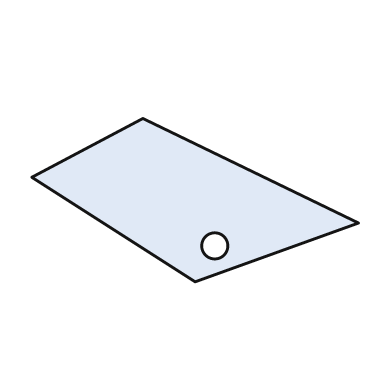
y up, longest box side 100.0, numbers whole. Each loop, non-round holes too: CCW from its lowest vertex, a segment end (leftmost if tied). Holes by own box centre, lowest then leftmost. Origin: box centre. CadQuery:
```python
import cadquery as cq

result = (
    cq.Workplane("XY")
    .moveTo(0.0, -25.0)
    .lineTo(50.0, -7.0)
    .lineTo(-16.0, 25.0)
    .lineTo(-50.0, 7.0)
    .close()
    .moveTo(6.0, -14.0)
    .circle(4.0)
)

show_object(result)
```